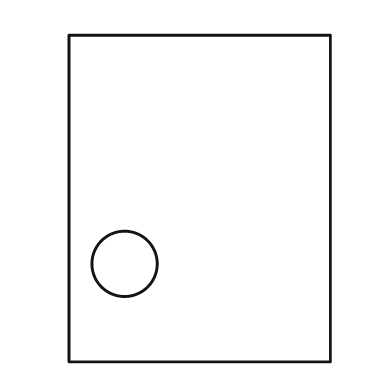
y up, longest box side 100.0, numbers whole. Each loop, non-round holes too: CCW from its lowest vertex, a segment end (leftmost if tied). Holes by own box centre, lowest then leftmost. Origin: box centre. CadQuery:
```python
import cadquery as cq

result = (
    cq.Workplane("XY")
    .moveTo(-40.0, -50.0)
    .lineTo(40.0, -50.0)
    .lineTo(40.0, 50.0)
    .lineTo(-40.0, 50.0)
    .close()
    .moveTo(-23.0, -20.0)
    .circle(10.0)
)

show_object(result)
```